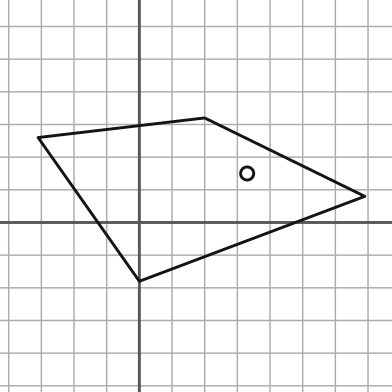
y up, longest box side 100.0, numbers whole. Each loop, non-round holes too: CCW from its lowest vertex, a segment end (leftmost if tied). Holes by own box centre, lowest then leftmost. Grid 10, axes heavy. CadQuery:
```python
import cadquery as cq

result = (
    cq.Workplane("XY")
    .moveTo(0.0, -18.0)
    .lineTo(69.0, 8.0)
    .lineTo(20.0, 32.0)
    .lineTo(-31.0, 26.0)
    .close()
    .moveTo(33.0, 15.0)
    .circle(2.0)
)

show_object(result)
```